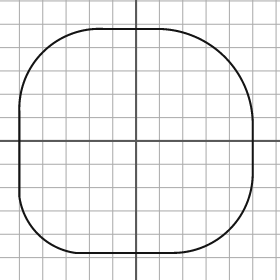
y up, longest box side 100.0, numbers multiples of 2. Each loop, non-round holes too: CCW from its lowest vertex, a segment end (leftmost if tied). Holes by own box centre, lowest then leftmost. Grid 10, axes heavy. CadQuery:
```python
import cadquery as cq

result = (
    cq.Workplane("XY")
    .moveTo(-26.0, -48.0)
    .lineTo(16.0, -48.0)
    .threePointArc((40.0, -38.0), (50.0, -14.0))
    .lineTo(50.0, 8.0)
    .threePointArc((38.0, 36.0), (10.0, 48.0))
    .lineTo(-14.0, 48.0)
    .threePointArc((-40.0, 38.0), (-50.0, 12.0))
    .lineTo(-50.0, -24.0)
    .threePointArc((-42.0, -40.0), (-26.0, -48.0))
    .close()
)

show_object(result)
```